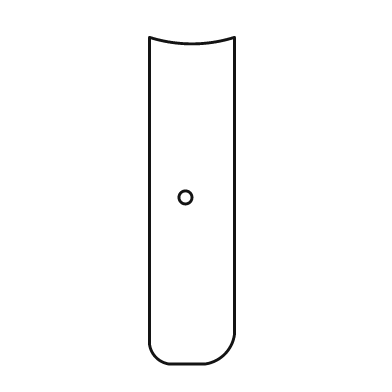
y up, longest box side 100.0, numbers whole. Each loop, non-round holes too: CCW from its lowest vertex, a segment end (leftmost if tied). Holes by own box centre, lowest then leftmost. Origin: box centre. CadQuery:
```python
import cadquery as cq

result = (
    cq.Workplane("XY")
    .moveTo(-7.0, -50.0)
    .lineTo(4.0, -50.0)
    .threePointArc((10.0, -47.0), (13.0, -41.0))
    .lineTo(13.0, 50.0)
    .threePointArc((0.0, 48.0), (-13.0, 50.0))
    .lineTo(-13.0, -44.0)
    .threePointArc((-11.0, -48.0), (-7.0, -50.0))
    .close()
    .moveTo(-2.0, 1.0)
    .circle(2.0)
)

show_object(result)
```